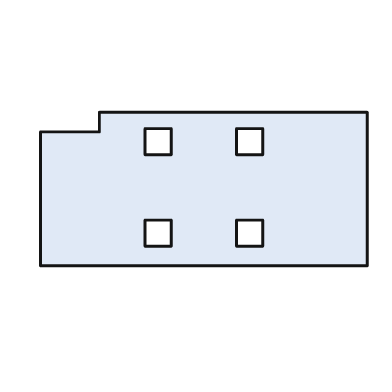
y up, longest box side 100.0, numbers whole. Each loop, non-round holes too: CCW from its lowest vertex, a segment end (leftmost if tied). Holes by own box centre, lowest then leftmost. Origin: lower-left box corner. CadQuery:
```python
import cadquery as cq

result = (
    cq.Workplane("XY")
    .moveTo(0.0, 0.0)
    .lineTo(100.0, 0.0)
    .lineTo(100.0, 47.0)
    .lineTo(18.0, 47.0)
    .lineTo(18.0, 41.0)
    .lineTo(0.0, 41.0)
    .close()
    .moveTo(32.0, 6.0)
    .lineTo(40.0, 6.0)
    .lineTo(40.0, 14.0)
    .lineTo(32.0, 14.0)
    .close()
    .moveTo(60.0, 6.0)
    .lineTo(68.0, 6.0)
    .lineTo(68.0, 14.0)
    .lineTo(60.0, 14.0)
    .close()
    .moveTo(32.0, 34.0)
    .lineTo(40.0, 34.0)
    .lineTo(40.0, 42.0)
    .lineTo(32.0, 42.0)
    .close()
    .moveTo(60.0, 34.0)
    .lineTo(68.0, 34.0)
    .lineTo(68.0, 42.0)
    .lineTo(60.0, 42.0)
    .close()
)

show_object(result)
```